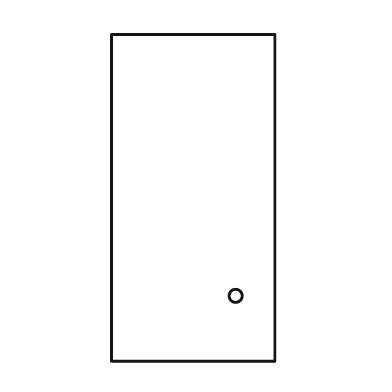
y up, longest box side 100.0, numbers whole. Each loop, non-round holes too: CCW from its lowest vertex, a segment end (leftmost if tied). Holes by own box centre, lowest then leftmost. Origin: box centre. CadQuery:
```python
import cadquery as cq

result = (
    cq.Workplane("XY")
    .moveTo(-25.0, -50.0)
    .lineTo(25.0, -50.0)
    .lineTo(25.0, 50.0)
    .lineTo(-25.0, 50.0)
    .close()
    .moveTo(13.0, -30.0)
    .circle(2.0)
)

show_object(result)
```